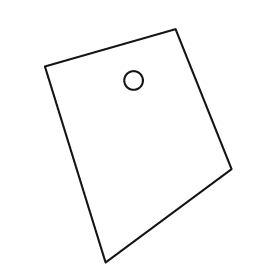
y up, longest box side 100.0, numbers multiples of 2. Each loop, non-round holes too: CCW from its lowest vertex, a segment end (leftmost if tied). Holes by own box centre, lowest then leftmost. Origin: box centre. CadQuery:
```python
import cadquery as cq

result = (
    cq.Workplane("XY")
    .moveTo(-14.0, -50.0)
    .lineTo(40.0, -10.0)
    .lineTo(16.0, 50.0)
    .lineTo(-40.0, 34.0)
    .close()
    .moveTo(-2.0, 28.0)
    .circle(4.0)
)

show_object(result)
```